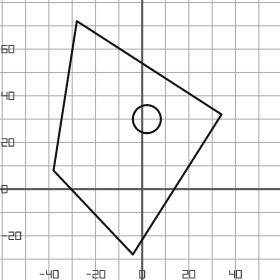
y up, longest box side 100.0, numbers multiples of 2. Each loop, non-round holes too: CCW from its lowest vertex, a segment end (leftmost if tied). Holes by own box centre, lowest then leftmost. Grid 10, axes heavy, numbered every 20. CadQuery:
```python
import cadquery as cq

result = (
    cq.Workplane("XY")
    .moveTo(-4.0, -28.0)
    .lineTo(34.0, 32.0)
    .lineTo(-28.0, 72.0)
    .lineTo(-38.0, 8.0)
    .close()
    .moveTo(2.0, 30.0)
    .circle(6.0)
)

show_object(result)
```